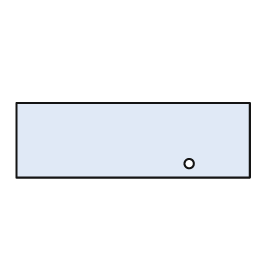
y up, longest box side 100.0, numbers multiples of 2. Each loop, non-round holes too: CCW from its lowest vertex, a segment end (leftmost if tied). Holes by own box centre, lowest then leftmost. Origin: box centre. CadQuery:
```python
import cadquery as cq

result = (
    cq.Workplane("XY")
    .moveTo(-50.0, -16.0)
    .lineTo(50.0, -16.0)
    .lineTo(50.0, 16.0)
    .lineTo(-50.0, 16.0)
    .close()
    .moveTo(24.0, -10.0)
    .circle(2.0)
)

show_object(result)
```